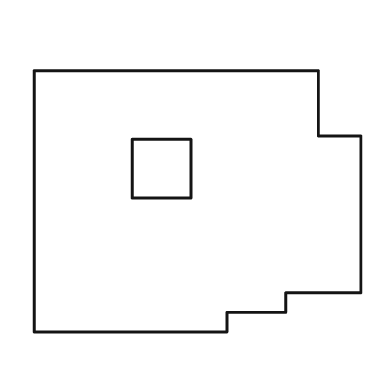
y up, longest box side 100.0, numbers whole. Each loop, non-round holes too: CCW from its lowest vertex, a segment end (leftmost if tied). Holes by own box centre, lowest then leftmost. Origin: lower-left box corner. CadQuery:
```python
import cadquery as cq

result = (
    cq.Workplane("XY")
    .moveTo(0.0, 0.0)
    .lineTo(59.0, 0.0)
    .lineTo(59.0, 6.0)
    .lineTo(77.0, 6.0)
    .lineTo(77.0, 12.0)
    .lineTo(100.0, 12.0)
    .lineTo(100.0, 60.0)
    .lineTo(87.0, 60.0)
    .lineTo(87.0, 80.0)
    .lineTo(0.0, 80.0)
    .close()
    .moveTo(30.0, 41.0)
    .lineTo(48.0, 41.0)
    .lineTo(48.0, 59.0)
    .lineTo(30.0, 59.0)
    .close()
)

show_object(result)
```